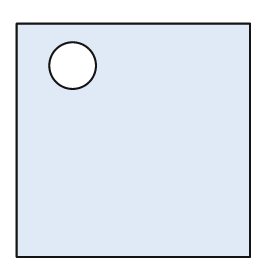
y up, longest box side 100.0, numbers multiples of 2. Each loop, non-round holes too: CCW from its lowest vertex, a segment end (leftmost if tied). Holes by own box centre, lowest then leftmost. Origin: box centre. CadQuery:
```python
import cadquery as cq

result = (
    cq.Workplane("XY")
    .moveTo(-50.0, -50.0)
    .lineTo(50.0, -50.0)
    .lineTo(50.0, 50.0)
    .lineTo(-50.0, 50.0)
    .close()
    .moveTo(-26.0, 32.0)
    .circle(10.0)
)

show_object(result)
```